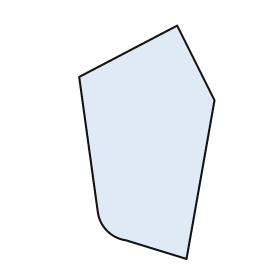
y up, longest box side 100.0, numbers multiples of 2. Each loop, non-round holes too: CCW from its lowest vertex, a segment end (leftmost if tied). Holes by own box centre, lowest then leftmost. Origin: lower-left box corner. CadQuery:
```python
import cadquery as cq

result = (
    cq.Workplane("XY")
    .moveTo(46.0, 0.0)
    .lineTo(58.0, 68.0)
    .lineTo(42.0, 100.0)
    .lineTo(0.0, 78.0)
    .lineTo(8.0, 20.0)
    .threePointArc((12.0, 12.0), (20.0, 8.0))
    .close()
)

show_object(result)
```